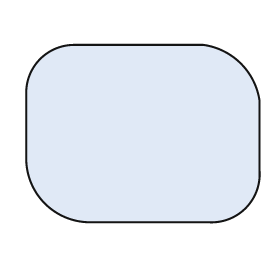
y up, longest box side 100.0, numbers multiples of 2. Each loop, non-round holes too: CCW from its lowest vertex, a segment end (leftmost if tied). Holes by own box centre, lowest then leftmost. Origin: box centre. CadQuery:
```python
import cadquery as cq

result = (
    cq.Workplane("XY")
    .moveTo(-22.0, -38.0)
    .lineTo(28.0, -38.0)
    .threePointArc((44.0, -32.0), (50.0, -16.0))
    .lineTo(50.0, 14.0)
    .threePointArc((42.0, 30.0), (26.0, 38.0))
    .lineTo(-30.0, 38.0)
    .threePointArc((-44.0, 32.0), (-50.0, 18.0))
    .lineTo(-50.0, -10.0)
    .threePointArc((-42.0, -30.0), (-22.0, -38.0))
    .close()
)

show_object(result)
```